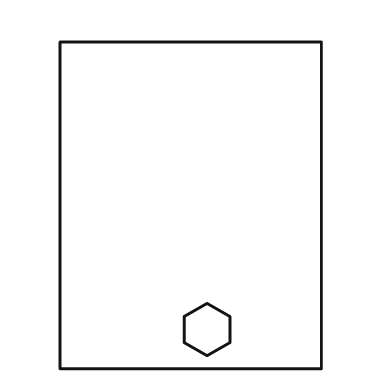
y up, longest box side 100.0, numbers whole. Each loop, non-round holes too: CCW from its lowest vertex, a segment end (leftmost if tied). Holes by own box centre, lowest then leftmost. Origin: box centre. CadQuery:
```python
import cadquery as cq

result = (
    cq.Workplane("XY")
    .moveTo(-40.0, -50.0)
    .lineTo(40.0, -50.0)
    .lineTo(40.0, 50.0)
    .lineTo(-40.0, 50.0)
    .close()
    .moveTo(5.0, -46.0)
    .lineTo(12.0, -42.0)
    .lineTo(12.0, -34.0)
    .lineTo(5.0, -30.0)
    .lineTo(-2.0, -34.0)
    .lineTo(-2.0, -42.0)
    .close()
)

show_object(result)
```